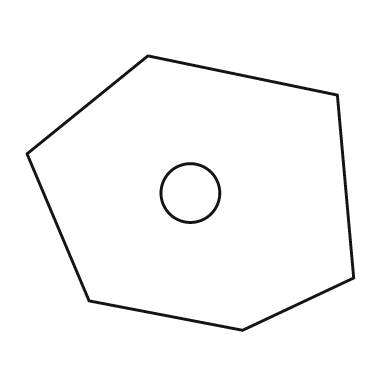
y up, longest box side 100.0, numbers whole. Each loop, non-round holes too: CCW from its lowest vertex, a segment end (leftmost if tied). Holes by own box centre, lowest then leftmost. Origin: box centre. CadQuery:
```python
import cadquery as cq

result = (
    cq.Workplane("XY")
    .moveTo(16.0, -42.0)
    .lineTo(50.0, -26.0)
    .lineTo(45.0, 30.0)
    .lineTo(-13.0, 42.0)
    .lineTo(-50.0, 12.0)
    .lineTo(-31.0, -33.0)
    .close()
    .moveTo(0.0, 0.0)
    .circle(9.0)
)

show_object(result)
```